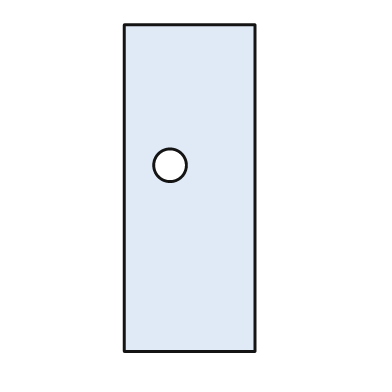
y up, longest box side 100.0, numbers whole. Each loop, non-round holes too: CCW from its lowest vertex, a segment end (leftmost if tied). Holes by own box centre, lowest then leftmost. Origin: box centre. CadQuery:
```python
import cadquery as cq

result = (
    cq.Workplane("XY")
    .moveTo(-20.0, -50.0)
    .lineTo(20.0, -50.0)
    .lineTo(20.0, 50.0)
    .lineTo(-20.0, 50.0)
    .close()
    .moveTo(-6.0, 7.0)
    .circle(5.0)
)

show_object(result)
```